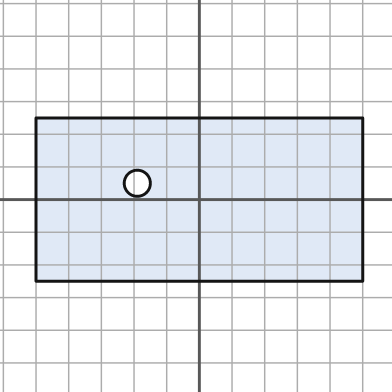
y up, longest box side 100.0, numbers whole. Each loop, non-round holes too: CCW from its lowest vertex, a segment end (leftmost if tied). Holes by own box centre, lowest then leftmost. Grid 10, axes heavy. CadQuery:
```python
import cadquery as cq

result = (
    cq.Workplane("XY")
    .moveTo(-50.0, -25.0)
    .lineTo(50.0, -25.0)
    .lineTo(50.0, 25.0)
    .lineTo(-50.0, 25.0)
    .close()
    .moveTo(-19.0, 5.0)
    .circle(4.0)
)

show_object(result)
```